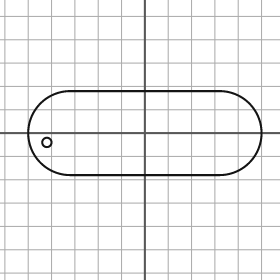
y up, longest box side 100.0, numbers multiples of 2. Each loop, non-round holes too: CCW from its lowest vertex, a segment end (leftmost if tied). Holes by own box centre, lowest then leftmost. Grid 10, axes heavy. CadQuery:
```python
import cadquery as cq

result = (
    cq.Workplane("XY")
    .moveTo(-32.0, -18.0)
    .lineTo(32.0, -18.0)
    .threePointArc((50.0, 0.0), (32.0, 18.0))
    .lineTo(-32.0, 18.0)
    .threePointArc((-50.0, 0.0), (-32.0, -18.0))
    .close()
    .moveTo(-42.0, -4.0)
    .circle(2.0)
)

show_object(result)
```